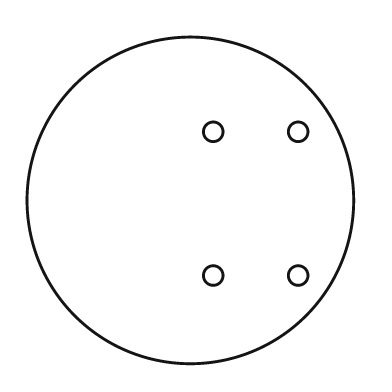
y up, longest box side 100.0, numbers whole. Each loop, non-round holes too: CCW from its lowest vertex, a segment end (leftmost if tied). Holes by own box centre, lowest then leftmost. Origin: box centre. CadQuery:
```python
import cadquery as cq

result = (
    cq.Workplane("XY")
    .moveTo(0.0, 0.0)
    .circle(50.0)
    .moveTo(7.0, -23.0)
    .circle(3.0)
    .moveTo(33.0, -23.0)
    .circle(3.0)
    .moveTo(7.0, 21.0)
    .circle(3.0)
    .moveTo(33.0, 21.0)
    .circle(3.0)
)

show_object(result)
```